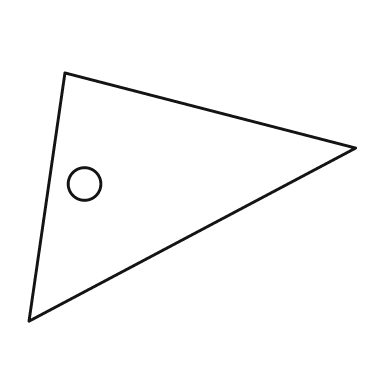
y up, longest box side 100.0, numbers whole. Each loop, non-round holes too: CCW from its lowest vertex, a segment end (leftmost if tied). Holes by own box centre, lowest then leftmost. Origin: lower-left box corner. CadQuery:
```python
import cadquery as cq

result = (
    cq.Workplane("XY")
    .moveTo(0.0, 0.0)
    .lineTo(100.0, 53.0)
    .lineTo(11.0, 76.0)
    .close()
    .moveTo(17.0, 42.0)
    .circle(5.0)
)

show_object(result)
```